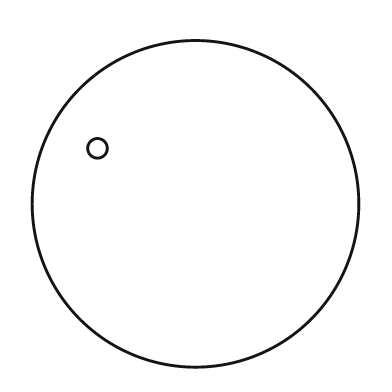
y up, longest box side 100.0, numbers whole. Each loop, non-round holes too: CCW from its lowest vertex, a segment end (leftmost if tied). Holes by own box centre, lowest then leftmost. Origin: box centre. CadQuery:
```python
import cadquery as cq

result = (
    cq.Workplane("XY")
    .moveTo(0.0, 0.0)
    .circle(50.0)
    .moveTo(-30.0, 17.0)
    .circle(3.0)
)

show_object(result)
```